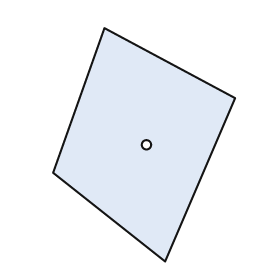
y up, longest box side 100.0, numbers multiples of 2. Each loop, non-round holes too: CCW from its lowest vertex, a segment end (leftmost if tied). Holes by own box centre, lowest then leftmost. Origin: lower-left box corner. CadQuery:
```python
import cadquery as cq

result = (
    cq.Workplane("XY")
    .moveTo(48.0, 0.0)
    .lineTo(78.0, 70.0)
    .lineTo(22.0, 100.0)
    .lineTo(0.0, 38.0)
    .close()
    .moveTo(40.0, 50.0)
    .circle(2.0)
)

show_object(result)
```